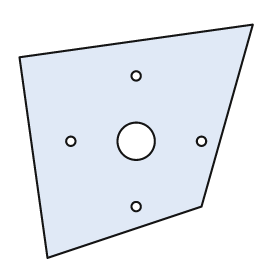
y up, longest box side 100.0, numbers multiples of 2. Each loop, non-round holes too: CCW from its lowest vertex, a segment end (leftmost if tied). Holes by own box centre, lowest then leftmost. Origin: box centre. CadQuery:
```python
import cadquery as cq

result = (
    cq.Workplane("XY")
    .moveTo(-38.0, -50.0)
    .lineTo(28.0, -28.0)
    .lineTo(50.0, 50.0)
    .lineTo(-50.0, 36.0)
    .close()
    .moveTo(0.0, -28.0)
    .circle(2.0)
    .moveTo(-28.0, 0.0)
    .circle(2.0)
    .moveTo(0.0, 0.0)
    .circle(8.0)
    .moveTo(28.0, 0.0)
    .circle(2.0)
    .moveTo(0.0, 28.0)
    .circle(2.0)
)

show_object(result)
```